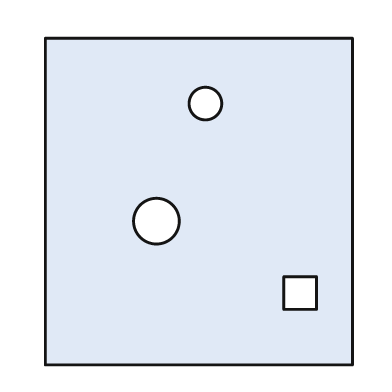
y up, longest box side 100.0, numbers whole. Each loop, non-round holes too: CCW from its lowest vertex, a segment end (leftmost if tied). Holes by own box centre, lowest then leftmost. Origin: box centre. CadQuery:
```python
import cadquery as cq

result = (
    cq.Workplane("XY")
    .moveTo(-47.0, -50.0)
    .lineTo(47.0, -50.0)
    .lineTo(47.0, 50.0)
    .lineTo(-47.0, 50.0)
    .close()
    .moveTo(26.0, -33.0)
    .lineTo(36.0, -33.0)
    .lineTo(36.0, -23.0)
    .lineTo(26.0, -23.0)
    .close()
    .moveTo(-13.0, -6.0)
    .circle(7.0)
    .moveTo(2.0, 30.0)
    .circle(5.0)
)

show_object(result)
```